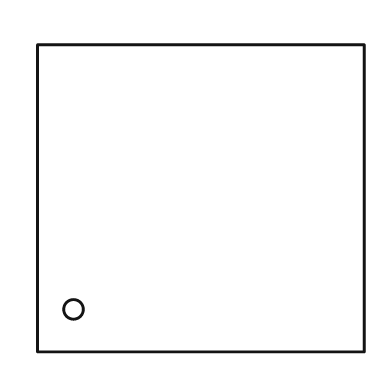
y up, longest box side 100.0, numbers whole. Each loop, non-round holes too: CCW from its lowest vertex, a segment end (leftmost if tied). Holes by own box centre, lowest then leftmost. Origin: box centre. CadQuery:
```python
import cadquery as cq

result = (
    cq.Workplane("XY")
    .moveTo(-50.0, -47.0)
    .lineTo(50.0, -47.0)
    .lineTo(50.0, 47.0)
    .lineTo(-50.0, 47.0)
    .close()
    .moveTo(-39.0, -34.0)
    .circle(3.0)
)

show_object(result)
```